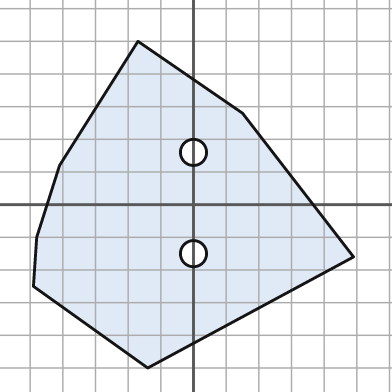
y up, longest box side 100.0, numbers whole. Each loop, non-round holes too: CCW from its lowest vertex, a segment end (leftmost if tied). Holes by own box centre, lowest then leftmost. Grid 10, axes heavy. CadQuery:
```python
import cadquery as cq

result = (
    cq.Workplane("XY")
    .moveTo(-14.0, -50.0)
    .lineTo(49.0, -16.0)
    .lineTo(15.0, 28.0)
    .lineTo(-17.0, 50.0)
    .lineTo(-41.0, 12.0)
    .lineTo(-48.0, -10.0)
    .lineTo(-49.0, -25.0)
    .close()
    .moveTo(0.0, -15.0)
    .circle(4.0)
    .moveTo(0.0, 16.0)
    .circle(4.0)
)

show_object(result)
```